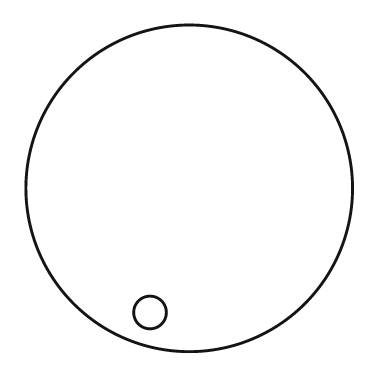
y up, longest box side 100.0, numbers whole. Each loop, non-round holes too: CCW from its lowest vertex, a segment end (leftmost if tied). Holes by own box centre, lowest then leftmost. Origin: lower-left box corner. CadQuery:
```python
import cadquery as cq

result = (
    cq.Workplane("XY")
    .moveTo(50.0, 50.0)
    .circle(50.0)
    .moveTo(38.0, 12.0)
    .circle(5.0)
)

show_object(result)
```